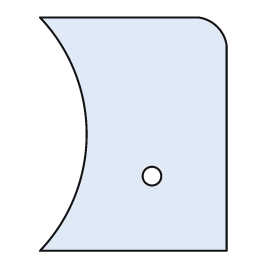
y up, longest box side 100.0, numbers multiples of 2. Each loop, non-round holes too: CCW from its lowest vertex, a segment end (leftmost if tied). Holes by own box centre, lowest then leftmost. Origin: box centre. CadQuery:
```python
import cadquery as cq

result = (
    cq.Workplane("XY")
    .moveTo(-40.0, -50.0)
    .lineTo(40.0, -50.0)
    .lineTo(40.0, 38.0)
    .threePointArc((36.0, 46.0), (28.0, 50.0))
    .lineTo(-40.0, 50.0)
    .threePointArc((-20.0, 0.0), (-40.0, -50.0))
    .close()
    .moveTo(8.0, -18.0)
    .circle(4.0)
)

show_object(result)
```